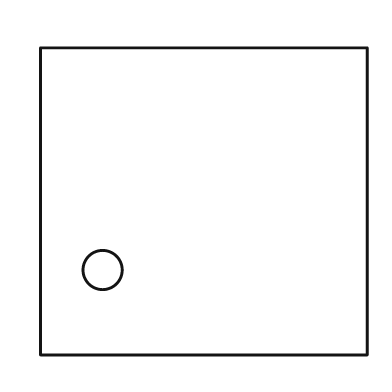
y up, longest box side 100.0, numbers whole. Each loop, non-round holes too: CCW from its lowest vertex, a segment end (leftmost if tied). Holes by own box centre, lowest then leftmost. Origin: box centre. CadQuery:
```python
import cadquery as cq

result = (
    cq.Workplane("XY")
    .moveTo(-50.0, -47.0)
    .lineTo(50.0, -47.0)
    .lineTo(50.0, 47.0)
    .lineTo(-50.0, 47.0)
    .close()
    .moveTo(-31.0, -21.0)
    .circle(6.0)
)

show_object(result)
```